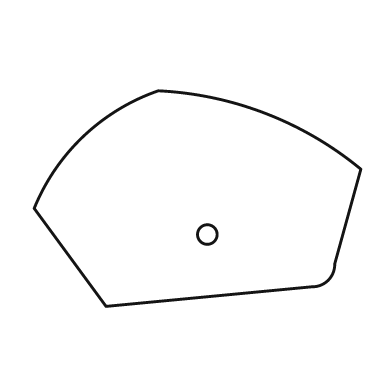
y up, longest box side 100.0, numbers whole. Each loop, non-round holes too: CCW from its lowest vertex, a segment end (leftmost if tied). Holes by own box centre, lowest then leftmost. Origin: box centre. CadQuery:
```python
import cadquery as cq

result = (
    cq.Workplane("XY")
    .moveTo(-28.0, -33.0)
    .lineTo(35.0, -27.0)
    .threePointArc((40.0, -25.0), (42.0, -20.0))
    .lineTo(50.0, 9.0)
    .threePointArc((21.0, 26.0), (-12.0, 33.0))
    .threePointArc((-35.0, 19.0), (-50.0, -3.0))
    .close()
    .moveTo(3.0, -11.0)
    .circle(3.0)
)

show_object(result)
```